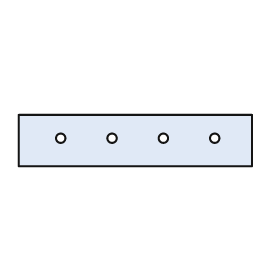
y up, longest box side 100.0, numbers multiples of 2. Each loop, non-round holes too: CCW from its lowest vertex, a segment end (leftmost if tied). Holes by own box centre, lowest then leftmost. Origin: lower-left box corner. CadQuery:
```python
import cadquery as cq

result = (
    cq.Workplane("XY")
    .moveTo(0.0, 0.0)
    .lineTo(100.0, 0.0)
    .lineTo(100.0, 22.0)
    .lineTo(0.0, 22.0)
    .close()
    .moveTo(18.0, 12.0)
    .circle(2.0)
    .moveTo(40.0, 12.0)
    .circle(2.0)
    .moveTo(62.0, 12.0)
    .circle(2.0)
    .moveTo(84.0, 12.0)
    .circle(2.0)
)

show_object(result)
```